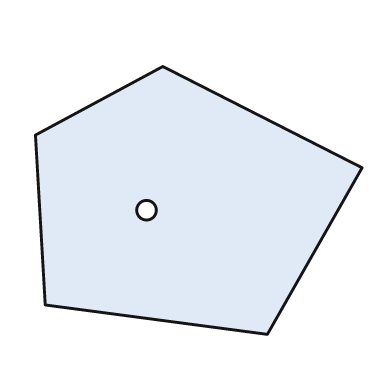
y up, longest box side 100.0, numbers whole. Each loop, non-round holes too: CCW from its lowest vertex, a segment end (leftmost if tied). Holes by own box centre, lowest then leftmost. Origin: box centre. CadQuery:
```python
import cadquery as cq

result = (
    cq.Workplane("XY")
    .moveTo(21.0, -41.0)
    .lineTo(50.0, 10.0)
    .lineTo(-11.0, 41.0)
    .lineTo(-50.0, 20.0)
    .lineTo(-47.0, -32.0)
    .close()
    .moveTo(-16.0, -3.0)
    .circle(3.0)
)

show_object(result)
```